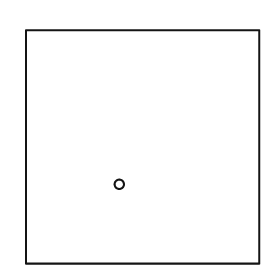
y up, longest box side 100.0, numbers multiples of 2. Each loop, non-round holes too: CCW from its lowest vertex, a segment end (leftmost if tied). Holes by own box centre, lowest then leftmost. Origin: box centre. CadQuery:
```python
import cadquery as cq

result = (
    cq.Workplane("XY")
    .moveTo(-50.0, -50.0)
    .lineTo(50.0, -50.0)
    .lineTo(50.0, 50.0)
    .lineTo(-50.0, 50.0)
    .close()
    .moveTo(-10.0, -16.0)
    .circle(2.0)
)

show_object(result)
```